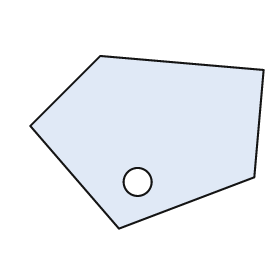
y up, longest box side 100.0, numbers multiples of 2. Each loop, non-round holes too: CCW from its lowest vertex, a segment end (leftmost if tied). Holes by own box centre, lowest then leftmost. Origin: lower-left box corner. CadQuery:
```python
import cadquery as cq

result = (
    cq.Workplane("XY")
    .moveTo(38.0, 0.0)
    .lineTo(96.0, 22.0)
    .lineTo(100.0, 68.0)
    .lineTo(30.0, 74.0)
    .lineTo(0.0, 44.0)
    .close()
    .moveTo(46.0, 20.0)
    .circle(6.0)
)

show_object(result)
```